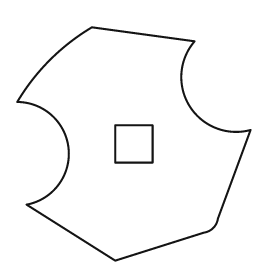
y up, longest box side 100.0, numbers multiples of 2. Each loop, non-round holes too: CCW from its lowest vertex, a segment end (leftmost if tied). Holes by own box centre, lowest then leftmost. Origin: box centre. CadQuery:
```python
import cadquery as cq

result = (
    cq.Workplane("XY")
    .moveTo(-8.0, -50.0)
    .lineTo(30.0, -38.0)
    .threePointArc((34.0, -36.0), (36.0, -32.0))
    .lineTo(50.0, 6.0)
    .threePointArc((24.0, 16.0), (26.0, 44.0))
    .lineTo(-18.0, 50.0)
    .threePointArc((-36.0, 36.0), (-50.0, 18.0))
    .threePointArc((-28.0, -2.0), (-46.0, -26.0))
    .close()
    .moveTo(-8.0, -8.0)
    .lineTo(8.0, -8.0)
    .lineTo(8.0, 8.0)
    .lineTo(-8.0, 8.0)
    .close()
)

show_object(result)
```